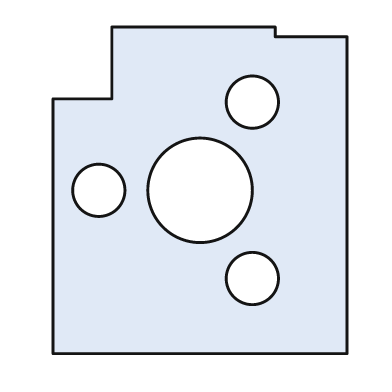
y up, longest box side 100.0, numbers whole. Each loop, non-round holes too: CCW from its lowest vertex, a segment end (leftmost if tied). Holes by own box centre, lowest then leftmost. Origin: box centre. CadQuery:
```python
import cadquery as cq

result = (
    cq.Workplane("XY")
    .moveTo(-45.0, -50.0)
    .lineTo(45.0, -50.0)
    .lineTo(45.0, 47.0)
    .lineTo(23.0, 47.0)
    .lineTo(23.0, 50.0)
    .lineTo(-27.0, 50.0)
    .lineTo(-27.0, 28.0)
    .lineTo(-45.0, 28.0)
    .close()
    .moveTo(16.0, -27.0)
    .circle(8.0)
    .moveTo(-31.0, 0.0)
    .circle(8.0)
    .moveTo(0.0, 0.0)
    .circle(16.0)
    .moveTo(16.0, 27.0)
    .circle(8.0)
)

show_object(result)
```